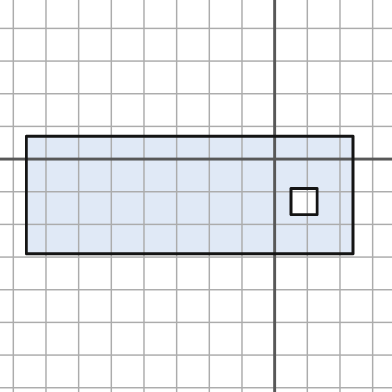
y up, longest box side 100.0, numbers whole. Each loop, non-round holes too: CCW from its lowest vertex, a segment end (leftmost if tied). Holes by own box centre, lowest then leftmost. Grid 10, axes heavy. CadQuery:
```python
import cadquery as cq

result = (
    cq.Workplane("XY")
    .moveTo(-76.0, -29.0)
    .lineTo(24.0, -29.0)
    .lineTo(24.0, 7.0)
    .lineTo(-76.0, 7.0)
    .close()
    .moveTo(5.0, -17.0)
    .lineTo(13.0, -17.0)
    .lineTo(13.0, -9.0)
    .lineTo(5.0, -9.0)
    .close()
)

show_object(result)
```